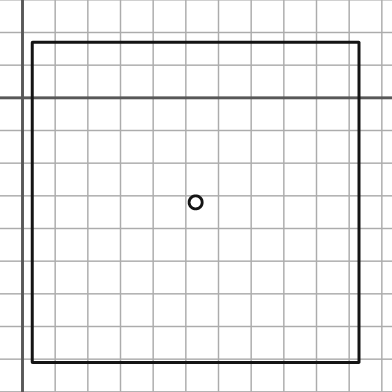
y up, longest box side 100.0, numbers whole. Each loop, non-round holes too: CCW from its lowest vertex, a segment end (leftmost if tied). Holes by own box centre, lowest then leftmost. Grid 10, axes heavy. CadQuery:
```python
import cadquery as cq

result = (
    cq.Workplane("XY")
    .moveTo(3.0, -81.0)
    .lineTo(103.0, -81.0)
    .lineTo(103.0, 17.0)
    .lineTo(3.0, 17.0)
    .close()
    .moveTo(53.0, -32.0)
    .circle(2.0)
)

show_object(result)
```